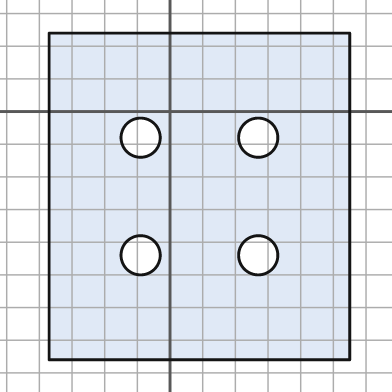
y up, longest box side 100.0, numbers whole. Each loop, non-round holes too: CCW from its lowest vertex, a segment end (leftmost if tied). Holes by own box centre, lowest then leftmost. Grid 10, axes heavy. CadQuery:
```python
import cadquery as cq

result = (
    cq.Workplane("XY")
    .moveTo(-37.0, -76.0)
    .lineTo(55.0, -76.0)
    .lineTo(55.0, 24.0)
    .lineTo(-37.0, 24.0)
    .close()
    .moveTo(-9.0, -44.0)
    .circle(6.0)
    .moveTo(27.0, -44.0)
    .circle(6.0)
    .moveTo(-9.0, -8.0)
    .circle(6.0)
    .moveTo(27.0, -8.0)
    .circle(6.0)
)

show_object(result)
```